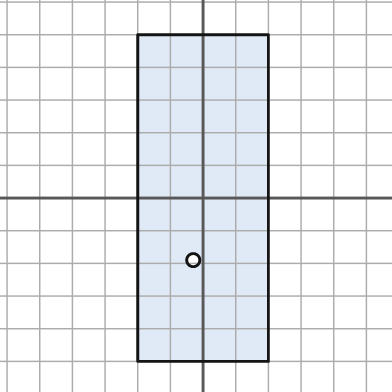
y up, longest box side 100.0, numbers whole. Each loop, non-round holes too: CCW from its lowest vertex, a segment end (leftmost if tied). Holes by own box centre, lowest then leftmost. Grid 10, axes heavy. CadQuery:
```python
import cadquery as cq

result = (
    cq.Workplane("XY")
    .moveTo(-20.0, -50.0)
    .lineTo(20.0, -50.0)
    .lineTo(20.0, 50.0)
    .lineTo(-20.0, 50.0)
    .close()
    .moveTo(-3.0, -19.0)
    .circle(2.0)
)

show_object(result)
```